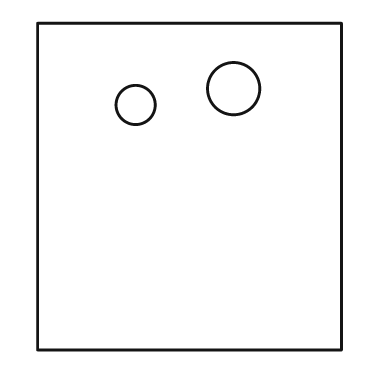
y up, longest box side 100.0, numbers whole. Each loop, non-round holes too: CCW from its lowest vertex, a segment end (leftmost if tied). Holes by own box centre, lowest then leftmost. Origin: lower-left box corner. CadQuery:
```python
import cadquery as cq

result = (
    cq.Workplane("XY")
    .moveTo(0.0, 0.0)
    .lineTo(93.0, 0.0)
    .lineTo(93.0, 100.0)
    .lineTo(0.0, 100.0)
    .close()
    .moveTo(30.0, 75.0)
    .circle(6.0)
    .moveTo(60.0, 80.0)
    .circle(8.0)
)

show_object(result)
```